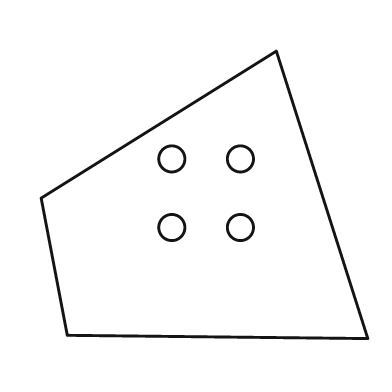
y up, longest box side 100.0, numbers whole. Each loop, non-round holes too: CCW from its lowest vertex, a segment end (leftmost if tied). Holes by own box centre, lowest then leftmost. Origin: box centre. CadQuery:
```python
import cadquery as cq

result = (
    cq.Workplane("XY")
    .moveTo(50.0, -44.0)
    .lineTo(22.0, 44.0)
    .lineTo(-50.0, -1.0)
    .lineTo(-42.0, -43.0)
    .close()
    .moveTo(-10.0, -10.0)
    .circle(4.0)
    .moveTo(11.0, -10.0)
    .circle(4.0)
    .moveTo(-10.0, 11.0)
    .circle(4.0)
    .moveTo(11.0, 11.0)
    .circle(4.0)
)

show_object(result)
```